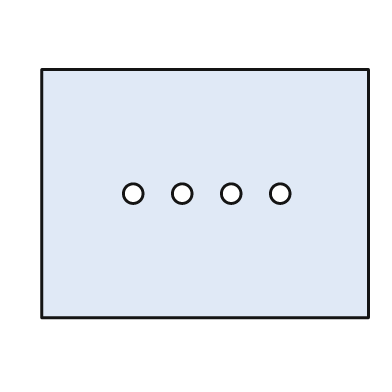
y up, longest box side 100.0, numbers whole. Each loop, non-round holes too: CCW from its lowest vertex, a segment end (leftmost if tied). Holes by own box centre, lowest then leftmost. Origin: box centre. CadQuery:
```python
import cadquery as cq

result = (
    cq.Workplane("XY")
    .moveTo(-50.0, -38.0)
    .lineTo(50.0, -38.0)
    .lineTo(50.0, 38.0)
    .lineTo(-50.0, 38.0)
    .close()
    .moveTo(-22.0, 0.0)
    .circle(3.0)
    .moveTo(-7.0, 0.0)
    .circle(3.0)
    .moveTo(8.0, 0.0)
    .circle(3.0)
    .moveTo(23.0, 0.0)
    .circle(3.0)
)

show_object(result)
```